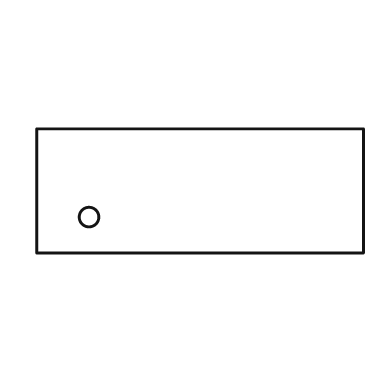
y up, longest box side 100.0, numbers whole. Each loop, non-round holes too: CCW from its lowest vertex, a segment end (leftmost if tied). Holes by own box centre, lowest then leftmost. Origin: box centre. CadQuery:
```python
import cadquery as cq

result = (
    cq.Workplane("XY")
    .moveTo(-50.0, -19.0)
    .lineTo(50.0, -19.0)
    .lineTo(50.0, 19.0)
    .lineTo(-50.0, 19.0)
    .close()
    .moveTo(-34.0, -8.0)
    .circle(3.0)
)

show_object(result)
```